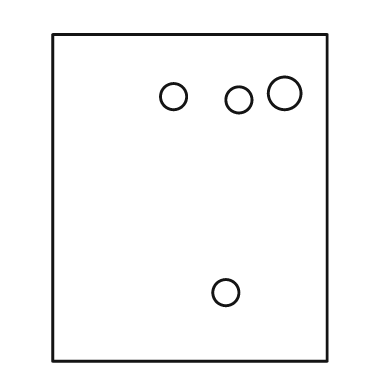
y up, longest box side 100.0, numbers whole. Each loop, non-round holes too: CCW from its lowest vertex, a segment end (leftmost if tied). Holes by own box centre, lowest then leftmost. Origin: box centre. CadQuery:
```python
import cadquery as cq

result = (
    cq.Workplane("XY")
    .moveTo(-42.0, -50.0)
    .lineTo(42.0, -50.0)
    .lineTo(42.0, 50.0)
    .lineTo(-42.0, 50.0)
    .close()
    .moveTo(11.0, -29.0)
    .circle(4.0)
    .moveTo(15.0, 30.0)
    .circle(4.0)
    .moveTo(-5.0, 31.0)
    .circle(4.0)
    .moveTo(29.0, 32.0)
    .circle(5.0)
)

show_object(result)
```